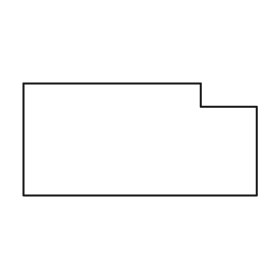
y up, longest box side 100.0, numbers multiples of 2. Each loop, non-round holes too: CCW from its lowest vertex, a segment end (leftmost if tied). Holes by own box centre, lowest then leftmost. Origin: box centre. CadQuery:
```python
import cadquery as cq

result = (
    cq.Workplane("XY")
    .moveTo(-50.0, -24.0)
    .lineTo(50.0, -24.0)
    .lineTo(50.0, 14.0)
    .lineTo(26.0, 14.0)
    .lineTo(26.0, 24.0)
    .lineTo(-50.0, 24.0)
    .close()
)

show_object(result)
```